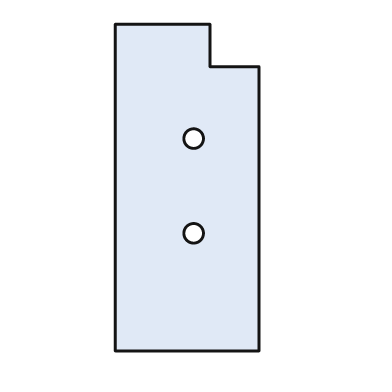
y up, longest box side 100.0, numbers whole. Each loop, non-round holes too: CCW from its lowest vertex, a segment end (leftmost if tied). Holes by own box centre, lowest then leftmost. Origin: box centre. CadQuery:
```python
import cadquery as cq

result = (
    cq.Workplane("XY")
    .moveTo(-22.0, -50.0)
    .lineTo(22.0, -50.0)
    .lineTo(22.0, 37.0)
    .lineTo(7.0, 37.0)
    .lineTo(7.0, 50.0)
    .lineTo(-22.0, 50.0)
    .close()
    .moveTo(2.0, -14.0)
    .circle(3.0)
    .moveTo(2.0, 15.0)
    .circle(3.0)
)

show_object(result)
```